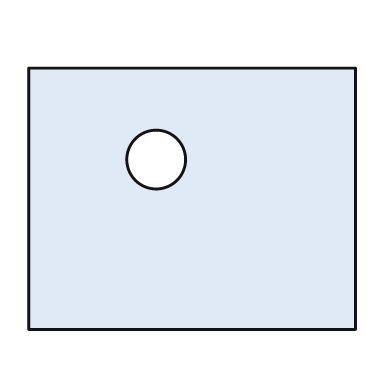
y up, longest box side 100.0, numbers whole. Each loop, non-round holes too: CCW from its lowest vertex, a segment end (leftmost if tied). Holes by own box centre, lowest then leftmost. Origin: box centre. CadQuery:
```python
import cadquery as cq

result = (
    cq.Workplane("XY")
    .moveTo(-50.0, -40.0)
    .lineTo(50.0, -40.0)
    .lineTo(50.0, 40.0)
    .lineTo(-50.0, 40.0)
    .close()
    .moveTo(-11.0, 12.0)
    .circle(9.0)
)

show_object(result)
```